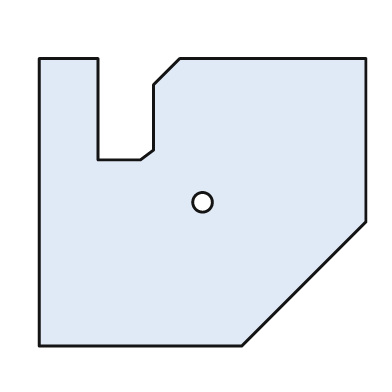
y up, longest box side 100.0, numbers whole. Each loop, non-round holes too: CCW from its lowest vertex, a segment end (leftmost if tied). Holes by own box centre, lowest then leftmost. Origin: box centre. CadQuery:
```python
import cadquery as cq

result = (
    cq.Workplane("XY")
    .moveTo(-50.0, -44.0)
    .lineTo(12.0, -44.0)
    .lineTo(50.0, -6.0)
    .lineTo(50.0, 44.0)
    .lineTo(-7.0, 44.0)
    .lineTo(-15.0, 36.0)
    .lineTo(-15.0, 16.0)
    .lineTo(-19.0, 13.0)
    .lineTo(-32.0, 13.0)
    .lineTo(-32.0, 44.0)
    .lineTo(-50.0, 44.0)
    .close()
    .moveTo(0.0, 0.0)
    .circle(3.0)
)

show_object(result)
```